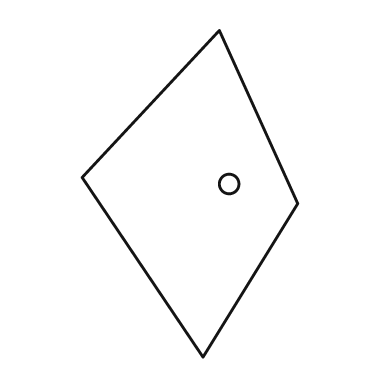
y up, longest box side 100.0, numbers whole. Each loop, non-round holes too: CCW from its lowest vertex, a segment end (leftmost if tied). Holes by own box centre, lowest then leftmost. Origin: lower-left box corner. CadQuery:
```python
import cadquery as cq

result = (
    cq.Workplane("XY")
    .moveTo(37.0, 0.0)
    .lineTo(66.0, 47.0)
    .lineTo(42.0, 100.0)
    .lineTo(0.0, 55.0)
    .close()
    .moveTo(45.0, 53.0)
    .circle(3.0)
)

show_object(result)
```